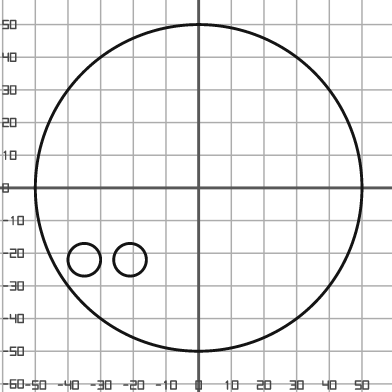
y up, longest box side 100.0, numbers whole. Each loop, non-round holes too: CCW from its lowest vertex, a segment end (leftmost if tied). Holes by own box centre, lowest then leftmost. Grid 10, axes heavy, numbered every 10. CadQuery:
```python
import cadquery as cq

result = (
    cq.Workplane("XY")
    .moveTo(0.0, 0.0)
    .circle(50.0)
    .moveTo(-35.0, -22.0)
    .circle(5.0)
    .moveTo(-21.0, -22.0)
    .circle(5.0)
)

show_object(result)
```